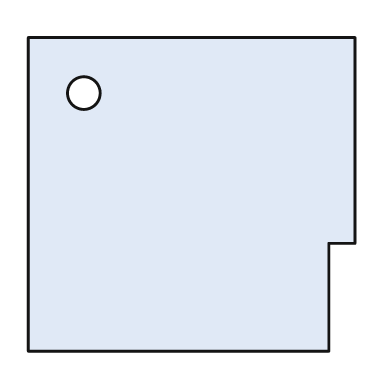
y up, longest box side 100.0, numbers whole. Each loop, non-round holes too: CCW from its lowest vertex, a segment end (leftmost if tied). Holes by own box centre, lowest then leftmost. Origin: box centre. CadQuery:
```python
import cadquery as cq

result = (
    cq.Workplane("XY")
    .moveTo(-50.0, -48.0)
    .lineTo(42.0, -48.0)
    .lineTo(42.0, -15.0)
    .lineTo(50.0, -15.0)
    .lineTo(50.0, 48.0)
    .lineTo(-50.0, 48.0)
    .close()
    .moveTo(-33.0, 31.0)
    .circle(5.0)
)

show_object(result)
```